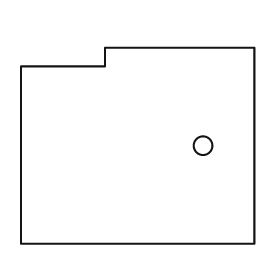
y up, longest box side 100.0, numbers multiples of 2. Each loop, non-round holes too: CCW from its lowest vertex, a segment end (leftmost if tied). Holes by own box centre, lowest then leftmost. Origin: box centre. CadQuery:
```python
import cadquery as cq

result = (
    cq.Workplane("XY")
    .moveTo(-50.0, -42.0)
    .lineTo(50.0, -42.0)
    .lineTo(50.0, 42.0)
    .lineTo(-14.0, 42.0)
    .lineTo(-14.0, 34.0)
    .lineTo(-50.0, 34.0)
    .close()
    .moveTo(28.0, 0.0)
    .circle(4.0)
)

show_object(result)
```